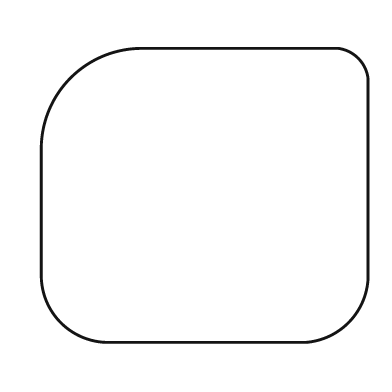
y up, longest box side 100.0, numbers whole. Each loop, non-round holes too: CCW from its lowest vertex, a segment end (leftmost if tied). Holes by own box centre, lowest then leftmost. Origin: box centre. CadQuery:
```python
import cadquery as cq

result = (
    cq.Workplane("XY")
    .moveTo(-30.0, -45.0)
    .lineTo(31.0, -45.0)
    .threePointArc((44.0, -39.0), (50.0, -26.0))
    .lineTo(50.0, 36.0)
    .threePointArc((47.0, 42.0), (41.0, 45.0))
    .lineTo(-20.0, 45.0)
    .threePointArc((-41.0, 36.0), (-50.0, 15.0))
    .lineTo(-50.0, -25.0)
    .threePointArc((-44.0, -39.0), (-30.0, -45.0))
    .close()
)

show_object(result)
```